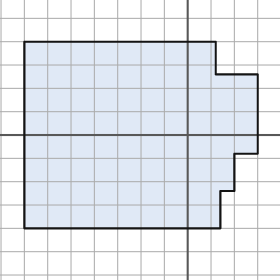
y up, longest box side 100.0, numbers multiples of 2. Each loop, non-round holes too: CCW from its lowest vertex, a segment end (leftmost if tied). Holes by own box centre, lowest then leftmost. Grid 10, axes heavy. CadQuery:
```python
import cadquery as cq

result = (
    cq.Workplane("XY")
    .moveTo(-70.0, -40.0)
    .lineTo(14.0, -40.0)
    .lineTo(14.0, -24.0)
    .lineTo(20.0, -24.0)
    .lineTo(20.0, -8.0)
    .lineTo(30.0, -8.0)
    .lineTo(30.0, 26.0)
    .lineTo(12.0, 26.0)
    .lineTo(12.0, 40.0)
    .lineTo(-70.0, 40.0)
    .close()
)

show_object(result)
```